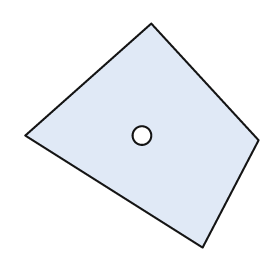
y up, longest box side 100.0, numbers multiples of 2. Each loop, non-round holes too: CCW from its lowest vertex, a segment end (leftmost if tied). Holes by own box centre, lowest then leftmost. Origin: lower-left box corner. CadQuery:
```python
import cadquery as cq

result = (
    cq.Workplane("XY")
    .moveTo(76.0, 0.0)
    .lineTo(100.0, 46.0)
    .lineTo(54.0, 96.0)
    .lineTo(0.0, 48.0)
    .close()
    .moveTo(50.0, 48.0)
    .circle(4.0)
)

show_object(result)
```